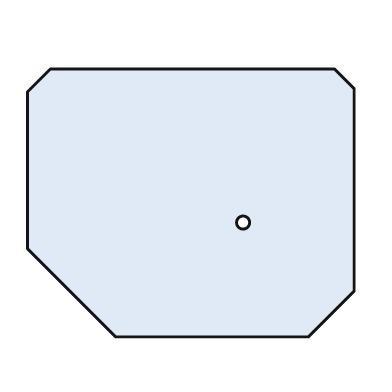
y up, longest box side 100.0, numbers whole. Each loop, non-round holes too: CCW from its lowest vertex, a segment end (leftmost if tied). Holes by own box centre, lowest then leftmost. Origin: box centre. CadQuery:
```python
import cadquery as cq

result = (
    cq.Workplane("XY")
    .moveTo(-23.0, -41.0)
    .lineTo(36.0, -41.0)
    .lineTo(50.0, -27.0)
    .lineTo(50.0, 35.0)
    .lineTo(44.0, 41.0)
    .lineTo(-43.0, 41.0)
    .lineTo(-50.0, 34.0)
    .lineTo(-50.0, -14.0)
    .close()
    .moveTo(16.0, -6.0)
    .circle(2.0)
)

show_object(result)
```